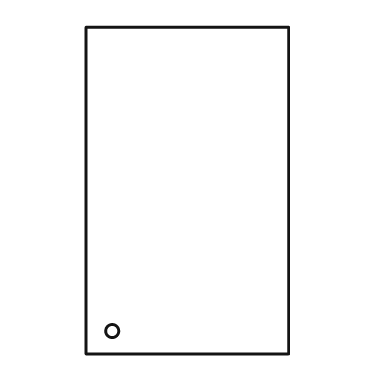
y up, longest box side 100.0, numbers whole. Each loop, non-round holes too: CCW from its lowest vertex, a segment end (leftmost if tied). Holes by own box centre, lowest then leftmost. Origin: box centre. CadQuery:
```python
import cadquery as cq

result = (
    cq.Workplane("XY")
    .moveTo(-31.0, -50.0)
    .lineTo(31.0, -50.0)
    .lineTo(31.0, 50.0)
    .lineTo(-31.0, 50.0)
    .close()
    .moveTo(-23.0, -43.0)
    .circle(2.0)
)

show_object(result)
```